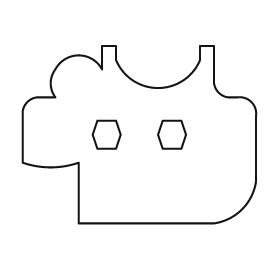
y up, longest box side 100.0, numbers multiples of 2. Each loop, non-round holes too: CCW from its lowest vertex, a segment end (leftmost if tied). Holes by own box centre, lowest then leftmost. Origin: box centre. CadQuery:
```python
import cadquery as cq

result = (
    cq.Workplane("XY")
    .moveTo(-26.0, -38.0)
    .lineTo(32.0, -38.0)
    .threePointArc((44.0, -32.0), (50.0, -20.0))
    .lineTo(50.0, 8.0)
    .threePointArc((48.0, 14.0), (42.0, 16.0))
    .lineTo(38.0, 16.0)
    .threePointArc((34.0, 18.0), (32.0, 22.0))
    .lineTo(32.0, 38.0)
    .lineTo(26.0, 38.0)
    .lineTo(26.0, 32.0)
    .threePointArc((8.0, 20.0), (-10.0, 32.0))
    .lineTo(-10.0, 38.0)
    .lineTo(-16.0, 38.0)
    .lineTo(-16.0, 28.0)
    .threePointArc((-26.0, 34.0), (-36.0, 28.0))
    .threePointArc((-38.0, 22.0), (-36.0, 16.0))
    .lineTo(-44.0, 16.0)
    .threePointArc((-48.0, 14.0), (-50.0, 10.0))
    .lineTo(-50.0, -12.0)
    .threePointArc((-38.0, -14.0), (-26.0, -12.0))
    .close()
    .moveTo(-18.0, -6.0)
    .lineTo(-10.0, -6.0)
    .lineTo(-8.0, 0.0)
    .lineTo(-10.0, 6.0)
    .lineTo(-18.0, 6.0)
    .lineTo(-20.0, 0.0)
    .close()
    .moveTo(10.0, -6.0)
    .lineTo(18.0, -6.0)
    .lineTo(20.0, 0.0)
    .lineTo(18.0, 6.0)
    .lineTo(10.0, 6.0)
    .lineTo(8.0, 0.0)
    .close()
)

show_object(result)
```